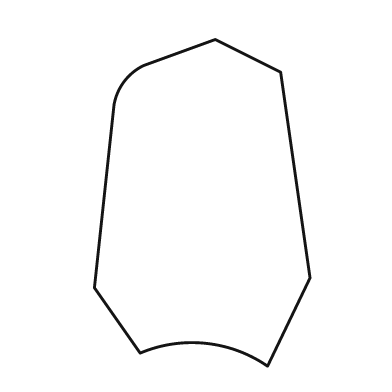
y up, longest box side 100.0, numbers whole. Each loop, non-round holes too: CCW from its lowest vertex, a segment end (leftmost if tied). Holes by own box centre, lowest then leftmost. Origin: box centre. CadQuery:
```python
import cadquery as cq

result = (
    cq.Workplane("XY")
    .moveTo(20.0, -50.0)
    .lineTo(33.0, -23.0)
    .lineTo(24.0, 40.0)
    .lineTo(4.0, 50.0)
    .lineTo(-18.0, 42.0)
    .threePointArc((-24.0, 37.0), (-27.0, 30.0))
    .lineTo(-33.0, -26.0)
    .lineTo(-19.0, -46.0)
    .threePointArc((1.0, -43.0), (20.0, -50.0))
    .close()
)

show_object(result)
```